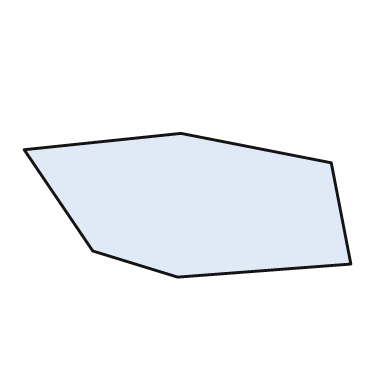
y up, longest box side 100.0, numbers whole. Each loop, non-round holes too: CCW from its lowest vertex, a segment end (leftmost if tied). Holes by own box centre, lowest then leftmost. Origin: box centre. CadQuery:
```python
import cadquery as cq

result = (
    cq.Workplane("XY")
    .moveTo(-3.0, -22.0)
    .lineTo(50.0, -18.0)
    .lineTo(44.0, 13.0)
    .lineTo(-2.0, 22.0)
    .lineTo(-50.0, 17.0)
    .lineTo(-29.0, -14.0)
    .close()
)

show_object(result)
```